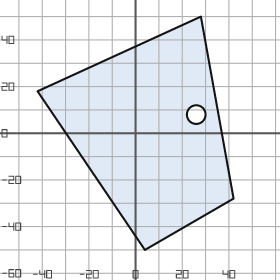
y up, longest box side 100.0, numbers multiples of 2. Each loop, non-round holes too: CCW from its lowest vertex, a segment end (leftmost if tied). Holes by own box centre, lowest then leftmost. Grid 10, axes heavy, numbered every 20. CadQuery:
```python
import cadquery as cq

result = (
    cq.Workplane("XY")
    .moveTo(4.0, -50.0)
    .lineTo(42.0, -28.0)
    .lineTo(28.0, 50.0)
    .lineTo(-42.0, 18.0)
    .close()
    .moveTo(26.0, 8.0)
    .circle(4.0)
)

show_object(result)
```